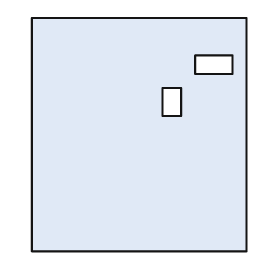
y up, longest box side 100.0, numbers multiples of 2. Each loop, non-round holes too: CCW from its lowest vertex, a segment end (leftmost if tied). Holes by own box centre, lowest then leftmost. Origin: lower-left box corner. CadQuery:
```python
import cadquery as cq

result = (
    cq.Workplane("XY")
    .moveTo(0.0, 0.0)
    .lineTo(92.0, 0.0)
    .lineTo(92.0, 100.0)
    .lineTo(0.0, 100.0)
    .close()
    .moveTo(56.0, 58.0)
    .lineTo(64.0, 58.0)
    .lineTo(64.0, 70.0)
    .lineTo(56.0, 70.0)
    .close()
    .moveTo(70.0, 76.0)
    .lineTo(86.0, 76.0)
    .lineTo(86.0, 84.0)
    .lineTo(70.0, 84.0)
    .close()
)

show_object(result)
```